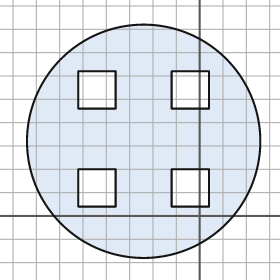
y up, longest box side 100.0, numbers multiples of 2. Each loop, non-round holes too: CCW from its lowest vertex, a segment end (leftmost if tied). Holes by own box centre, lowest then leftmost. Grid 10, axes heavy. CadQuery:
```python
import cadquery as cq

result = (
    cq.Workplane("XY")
    .moveTo(-24.0, 32.0)
    .circle(50.0)
    .moveTo(-52.0, 4.0)
    .lineTo(-36.0, 4.0)
    .lineTo(-36.0, 20.0)
    .lineTo(-52.0, 20.0)
    .close()
    .moveTo(-12.0, 4.0)
    .lineTo(4.0, 4.0)
    .lineTo(4.0, 20.0)
    .lineTo(-12.0, 20.0)
    .close()
    .moveTo(-52.0, 46.0)
    .lineTo(-36.0, 46.0)
    .lineTo(-36.0, 62.0)
    .lineTo(-52.0, 62.0)
    .close()
    .moveTo(-12.0, 46.0)
    .lineTo(4.0, 46.0)
    .lineTo(4.0, 62.0)
    .lineTo(-12.0, 62.0)
    .close()
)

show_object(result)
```